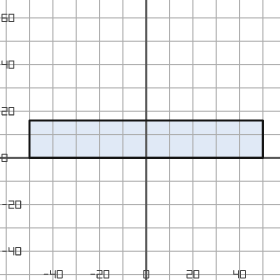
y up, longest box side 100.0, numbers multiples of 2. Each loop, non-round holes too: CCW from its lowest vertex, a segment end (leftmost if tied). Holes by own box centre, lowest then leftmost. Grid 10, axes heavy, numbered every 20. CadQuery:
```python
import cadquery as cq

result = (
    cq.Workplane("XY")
    .moveTo(-50.0, 0.0)
    .lineTo(50.0, 0.0)
    .lineTo(50.0, 16.0)
    .lineTo(-50.0, 16.0)
    .close()
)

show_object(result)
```